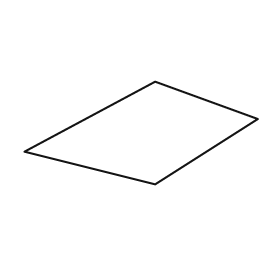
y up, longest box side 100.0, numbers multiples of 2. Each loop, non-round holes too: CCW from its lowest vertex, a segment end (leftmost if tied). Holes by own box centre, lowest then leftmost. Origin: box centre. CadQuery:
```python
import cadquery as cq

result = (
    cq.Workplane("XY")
    .moveTo(6.0, -22.0)
    .lineTo(50.0, 6.0)
    .lineTo(6.0, 22.0)
    .lineTo(-50.0, -8.0)
    .close()
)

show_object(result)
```